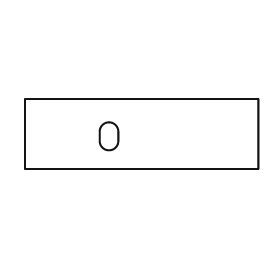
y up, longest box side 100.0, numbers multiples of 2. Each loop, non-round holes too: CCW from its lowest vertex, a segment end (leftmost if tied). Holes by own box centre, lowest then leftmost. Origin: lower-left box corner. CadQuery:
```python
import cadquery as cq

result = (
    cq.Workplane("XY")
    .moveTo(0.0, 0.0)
    .lineTo(100.0, 0.0)
    .lineTo(100.0, 30.0)
    .lineTo(0.0, 30.0)
    .close()
    .moveTo(32.0, 12.0)
    .threePointArc((36.0, 8.0), (40.0, 12.0))
    .lineTo(40.0, 16.0)
    .threePointArc((36.0, 20.0), (32.0, 16.0))
    .close()
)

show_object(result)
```